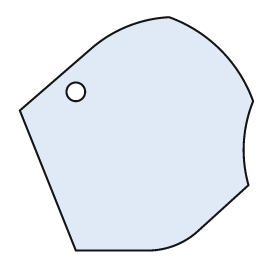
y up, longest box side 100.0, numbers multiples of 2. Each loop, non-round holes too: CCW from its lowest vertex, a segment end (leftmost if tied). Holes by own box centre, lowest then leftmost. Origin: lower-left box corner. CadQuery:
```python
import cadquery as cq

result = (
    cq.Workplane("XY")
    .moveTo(24.0, 0.0)
    .lineTo(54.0, 0.0)
    .threePointArc((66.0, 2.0), (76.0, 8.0))
    .lineTo(98.0, 28.0)
    .threePointArc((96.0, 46.0), (100.0, 64.0))
    .threePointArc((86.0, 86.0), (64.0, 100.0))
    .threePointArc((46.0, 96.0), (30.0, 86.0))
    .lineTo(0.0, 60.0)
    .close()
    .moveTo(24.0, 68.0)
    .circle(4.0)
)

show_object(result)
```